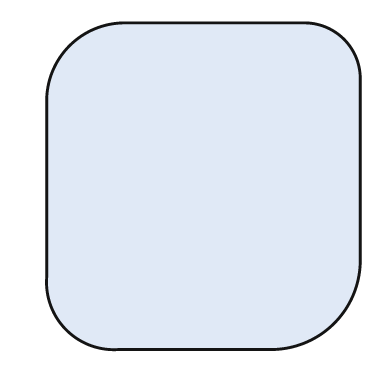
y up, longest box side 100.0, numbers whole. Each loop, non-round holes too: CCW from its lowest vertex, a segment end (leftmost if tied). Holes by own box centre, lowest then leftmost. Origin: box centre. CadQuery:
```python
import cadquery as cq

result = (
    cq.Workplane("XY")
    .moveTo(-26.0, -50.0)
    .lineTo(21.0, -50.0)
    .threePointArc((40.0, -42.0), (48.0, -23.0))
    .lineTo(48.0, 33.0)
    .threePointArc((43.0, 45.0), (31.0, 50.0))
    .lineTo(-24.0, 50.0)
    .threePointArc((-41.0, 43.0), (-48.0, 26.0))
    .lineTo(-48.0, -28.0)
    .threePointArc((-42.0, -44.0), (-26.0, -50.0))
    .close()
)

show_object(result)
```